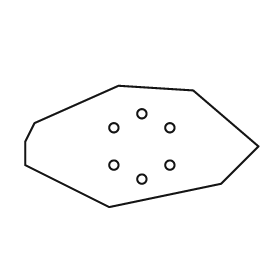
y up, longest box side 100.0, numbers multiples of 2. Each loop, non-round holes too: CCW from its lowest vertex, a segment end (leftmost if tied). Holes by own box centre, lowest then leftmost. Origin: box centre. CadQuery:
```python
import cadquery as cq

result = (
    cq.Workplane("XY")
    .moveTo(-14.0, -26.0)
    .lineTo(34.0, -16.0)
    .lineTo(50.0, 0.0)
    .lineTo(22.0, 24.0)
    .lineTo(-10.0, 26.0)
    .lineTo(-46.0, 10.0)
    .lineTo(-50.0, 2.0)
    .lineTo(-50.0, -8.0)
    .close()
    .moveTo(0.0, -14.0)
    .circle(2.0)
    .moveTo(-12.0, -8.0)
    .circle(2.0)
    .moveTo(12.0, -8.0)
    .circle(2.0)
    .moveTo(-12.0, 8.0)
    .circle(2.0)
    .moveTo(12.0, 8.0)
    .circle(2.0)
    .moveTo(0.0, 14.0)
    .circle(2.0)
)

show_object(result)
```